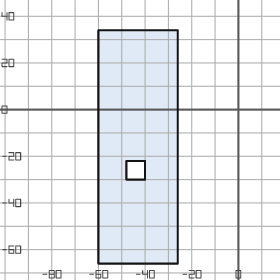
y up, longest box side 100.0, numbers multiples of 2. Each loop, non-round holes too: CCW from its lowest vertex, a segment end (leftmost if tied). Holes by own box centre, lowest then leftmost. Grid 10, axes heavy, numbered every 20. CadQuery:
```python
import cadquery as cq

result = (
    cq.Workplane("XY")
    .moveTo(-60.0, -66.0)
    .lineTo(-26.0, -66.0)
    .lineTo(-26.0, 34.0)
    .lineTo(-60.0, 34.0)
    .close()
    .moveTo(-48.0, -30.0)
    .lineTo(-40.0, -30.0)
    .lineTo(-40.0, -22.0)
    .lineTo(-48.0, -22.0)
    .close()
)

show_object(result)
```